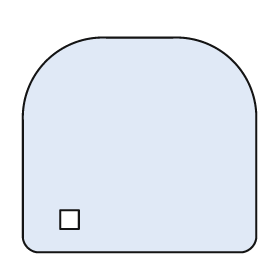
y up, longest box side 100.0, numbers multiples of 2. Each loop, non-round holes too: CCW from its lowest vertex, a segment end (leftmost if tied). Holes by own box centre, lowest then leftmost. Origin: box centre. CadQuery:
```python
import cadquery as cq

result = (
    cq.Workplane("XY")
    .moveTo(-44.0, -46.0)
    .lineTo(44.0, -46.0)
    .threePointArc((48.0, -44.0), (50.0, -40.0))
    .lineTo(50.0, 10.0)
    .threePointArc((40.0, 36.0), (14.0, 46.0))
    .lineTo(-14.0, 46.0)
    .threePointArc((-40.0, 36.0), (-50.0, 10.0))
    .lineTo(-50.0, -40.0)
    .threePointArc((-48.0, -44.0), (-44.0, -46.0))
    .close()
    .moveTo(-34.0, -36.0)
    .lineTo(-26.0, -36.0)
    .lineTo(-26.0, -28.0)
    .lineTo(-34.0, -28.0)
    .close()
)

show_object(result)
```